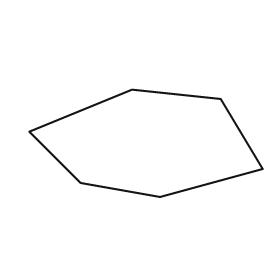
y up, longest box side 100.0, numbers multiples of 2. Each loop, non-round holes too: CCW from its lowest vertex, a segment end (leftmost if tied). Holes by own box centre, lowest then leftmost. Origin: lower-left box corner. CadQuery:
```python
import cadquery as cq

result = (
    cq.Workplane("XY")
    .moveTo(56.0, 0.0)
    .lineTo(100.0, 12.0)
    .lineTo(82.0, 42.0)
    .lineTo(44.0, 46.0)
    .lineTo(0.0, 28.0)
    .lineTo(22.0, 6.0)
    .close()
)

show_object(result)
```